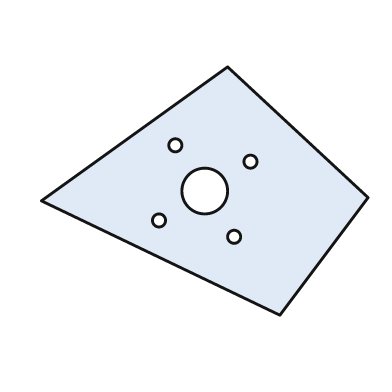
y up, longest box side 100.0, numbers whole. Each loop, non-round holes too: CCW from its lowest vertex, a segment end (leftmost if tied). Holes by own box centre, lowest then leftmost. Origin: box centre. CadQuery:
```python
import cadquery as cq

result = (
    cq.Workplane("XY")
    .moveTo(23.0, -38.0)
    .lineTo(50.0, -2.0)
    .lineTo(7.0, 38.0)
    .lineTo(-50.0, -3.0)
    .close()
    .moveTo(9.0, -14.0)
    .circle(2.0)
    .moveTo(-14.0, -9.0)
    .circle(2.0)
    .moveTo(0.0, 0.0)
    .circle(7.0)
    .moveTo(14.0, 9.0)
    .circle(2.0)
    .moveTo(-9.0, 14.0)
    .circle(2.0)
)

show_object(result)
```